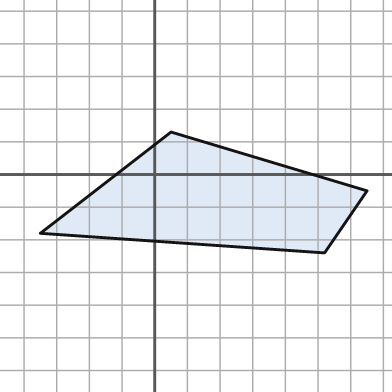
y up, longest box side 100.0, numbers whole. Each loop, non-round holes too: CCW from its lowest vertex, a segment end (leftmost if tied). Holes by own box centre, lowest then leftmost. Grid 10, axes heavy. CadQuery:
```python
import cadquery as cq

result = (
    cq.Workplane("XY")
    .moveTo(52.0, -24.0)
    .lineTo(65.0, -5.0)
    .lineTo(5.0, 13.0)
    .lineTo(-35.0, -18.0)
    .close()
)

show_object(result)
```